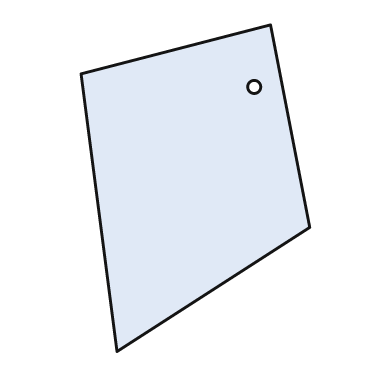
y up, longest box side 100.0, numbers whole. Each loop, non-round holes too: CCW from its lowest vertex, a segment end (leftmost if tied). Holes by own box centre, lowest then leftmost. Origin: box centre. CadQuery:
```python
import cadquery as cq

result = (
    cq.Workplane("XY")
    .moveTo(-24.0, -50.0)
    .lineTo(35.0, -12.0)
    .lineTo(23.0, 50.0)
    .lineTo(-35.0, 35.0)
    .close()
    .moveTo(18.0, 31.0)
    .circle(2.0)
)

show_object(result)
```